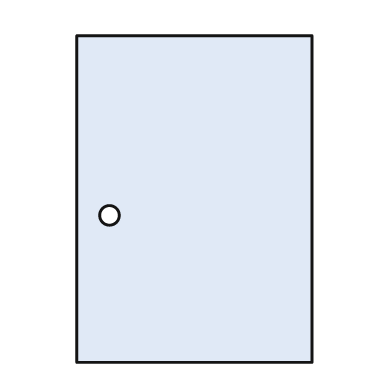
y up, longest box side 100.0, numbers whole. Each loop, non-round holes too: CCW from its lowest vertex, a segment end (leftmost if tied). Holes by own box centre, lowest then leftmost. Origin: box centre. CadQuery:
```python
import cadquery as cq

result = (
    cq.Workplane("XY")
    .moveTo(-36.0, -50.0)
    .lineTo(36.0, -50.0)
    .lineTo(36.0, 50.0)
    .lineTo(-36.0, 50.0)
    .close()
    .moveTo(-26.0, -5.0)
    .circle(3.0)
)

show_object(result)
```